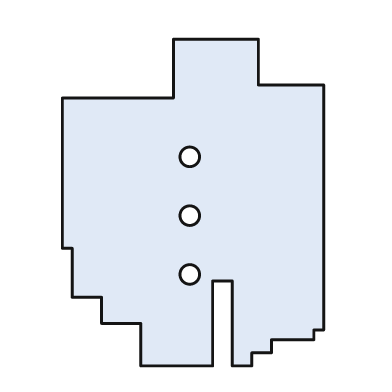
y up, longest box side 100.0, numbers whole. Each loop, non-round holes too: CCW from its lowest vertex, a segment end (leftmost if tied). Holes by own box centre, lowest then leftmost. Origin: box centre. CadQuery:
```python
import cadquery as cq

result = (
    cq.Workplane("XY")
    .moveTo(-16.0, -50.0)
    .lineTo(6.0, -50.0)
    .lineTo(6.0, -24.0)
    .lineTo(12.0, -24.0)
    .lineTo(12.0, -50.0)
    .lineTo(18.0, -50.0)
    .lineTo(18.0, -46.0)
    .lineTo(24.0, -46.0)
    .lineTo(24.0, -42.0)
    .lineTo(37.0, -42.0)
    .lineTo(37.0, -39.0)
    .lineTo(40.0, -39.0)
    .lineTo(40.0, 36.0)
    .lineTo(20.0, 36.0)
    .lineTo(20.0, 50.0)
    .lineTo(-6.0, 50.0)
    .lineTo(-6.0, 32.0)
    .lineTo(-40.0, 32.0)
    .lineTo(-40.0, -14.0)
    .lineTo(-37.0, -14.0)
    .lineTo(-37.0, -29.0)
    .lineTo(-28.0, -29.0)
    .lineTo(-28.0, -37.0)
    .lineTo(-16.0, -37.0)
    .close()
    .moveTo(-1.0, -22.0)
    .circle(3.0)
    .moveTo(-1.0, -4.0)
    .circle(3.0)
    .moveTo(-1.0, 14.0)
    .circle(3.0)
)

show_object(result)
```